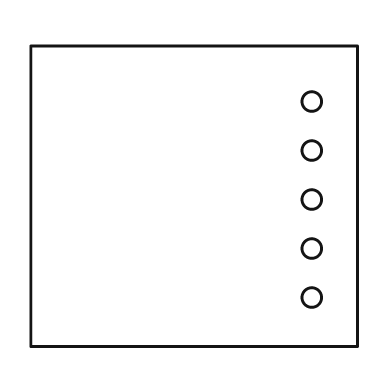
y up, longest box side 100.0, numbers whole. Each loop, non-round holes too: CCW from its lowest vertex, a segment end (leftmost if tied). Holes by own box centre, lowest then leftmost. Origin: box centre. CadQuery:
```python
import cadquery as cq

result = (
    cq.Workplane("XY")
    .moveTo(-50.0, -46.0)
    .lineTo(50.0, -46.0)
    .lineTo(50.0, 46.0)
    .lineTo(-50.0, 46.0)
    .close()
    .moveTo(36.0, -31.0)
    .circle(3.0)
    .moveTo(36.0, -16.0)
    .circle(3.0)
    .moveTo(36.0, -1.0)
    .circle(3.0)
    .moveTo(36.0, 14.0)
    .circle(3.0)
    .moveTo(36.0, 29.0)
    .circle(3.0)
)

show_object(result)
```